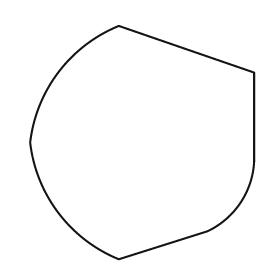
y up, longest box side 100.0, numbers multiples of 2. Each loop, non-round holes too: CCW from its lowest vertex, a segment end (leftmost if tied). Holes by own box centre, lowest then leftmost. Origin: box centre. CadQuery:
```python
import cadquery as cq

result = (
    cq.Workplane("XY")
    .moveTo(-10.0, -50.0)
    .lineTo(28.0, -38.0)
    .threePointArc((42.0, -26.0), (48.0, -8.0))
    .lineTo(48.0, 30.0)
    .lineTo(-10.0, 50.0)
    .threePointArc((-36.0, 30.0), (-48.0, 0.0))
    .threePointArc((-36.0, -30.0), (-10.0, -50.0))
    .close()
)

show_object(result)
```